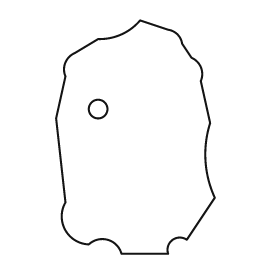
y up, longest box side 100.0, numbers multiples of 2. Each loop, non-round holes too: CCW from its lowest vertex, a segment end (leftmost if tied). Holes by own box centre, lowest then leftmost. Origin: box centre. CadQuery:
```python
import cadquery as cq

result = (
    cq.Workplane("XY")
    .moveTo(-6.0, -50.0)
    .lineTo(14.0, -50.0)
    .threePointArc((16.0, -44.0), (22.0, -44.0))
    .lineTo(34.0, -26.0)
    .threePointArc((30.0, -10.0), (32.0, 6.0))
    .lineTo(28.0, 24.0)
    .threePointArc((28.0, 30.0), (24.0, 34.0))
    .lineTo(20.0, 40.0)
    .threePointArc((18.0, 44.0), (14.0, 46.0))
    .lineTo(2.0, 50.0)
    .threePointArc((-6.0, 44.0), (-16.0, 42.0))
    .lineTo(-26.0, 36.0)
    .threePointArc((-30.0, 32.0), (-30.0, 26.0))
    .lineTo(-34.0, 8.0)
    .lineTo(-30.0, -28.0)
    .threePointArc((-30.0, -40.0), (-20.0, -46.0))
    .threePointArc((-12.0, -44.0), (-6.0, -50.0))
    .close()
    .moveTo(-16.0, 12.0)
    .circle(4.0)
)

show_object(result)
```